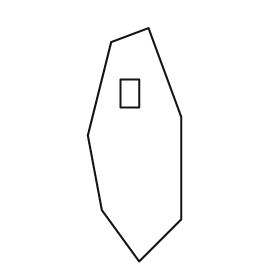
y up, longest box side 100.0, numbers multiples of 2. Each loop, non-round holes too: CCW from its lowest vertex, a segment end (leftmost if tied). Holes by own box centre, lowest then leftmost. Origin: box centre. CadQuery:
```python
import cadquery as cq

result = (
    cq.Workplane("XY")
    .moveTo(2.0, -50.0)
    .lineTo(20.0, -32.0)
    .lineTo(20.0, 12.0)
    .lineTo(6.0, 50.0)
    .lineTo(-10.0, 44.0)
    .lineTo(-20.0, 4.0)
    .lineTo(-14.0, -28.0)
    .close()
    .moveTo(-6.0, 16.0)
    .lineTo(2.0, 16.0)
    .lineTo(2.0, 28.0)
    .lineTo(-6.0, 28.0)
    .close()
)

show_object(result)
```